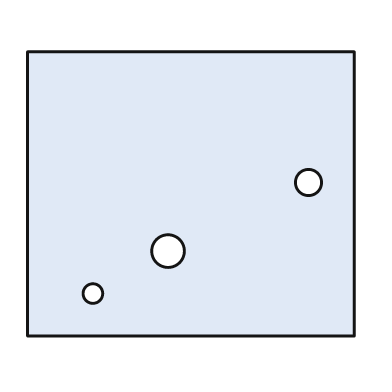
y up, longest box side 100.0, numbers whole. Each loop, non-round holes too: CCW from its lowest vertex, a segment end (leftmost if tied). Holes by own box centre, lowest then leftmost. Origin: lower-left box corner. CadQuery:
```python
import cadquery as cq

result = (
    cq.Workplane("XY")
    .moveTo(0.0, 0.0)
    .lineTo(100.0, 0.0)
    .lineTo(100.0, 87.0)
    .lineTo(0.0, 87.0)
    .close()
    .moveTo(20.0, 13.0)
    .circle(3.0)
    .moveTo(43.0, 26.0)
    .circle(5.0)
    .moveTo(86.0, 47.0)
    .circle(4.0)
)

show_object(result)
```